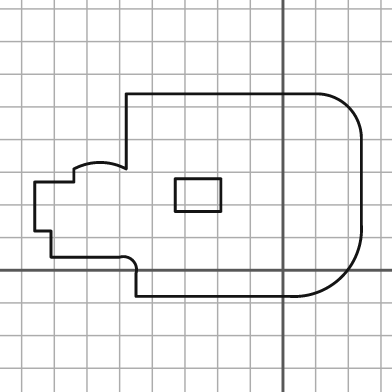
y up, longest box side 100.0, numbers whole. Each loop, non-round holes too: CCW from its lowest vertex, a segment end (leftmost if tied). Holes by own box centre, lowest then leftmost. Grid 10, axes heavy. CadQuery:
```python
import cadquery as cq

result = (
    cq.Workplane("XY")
    .moveTo(-45.0, -8.0)
    .lineTo(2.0, -8.0)
    .threePointArc((18.0, -2.0), (24.0, 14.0))
    .lineTo(24.0, 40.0)
    .threePointArc((20.0, 50.0), (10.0, 54.0))
    .lineTo(-48.0, 54.0)
    .lineTo(-48.0, 31.0)
    .threePointArc((-56.0, 33.0), (-64.0, 31.0))
    .lineTo(-64.0, 27.0)
    .lineTo(-76.0, 27.0)
    .lineTo(-76.0, 12.0)
    .lineTo(-71.0, 12.0)
    .lineTo(-71.0, 4.0)
    .lineTo(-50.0, 4.0)
    .threePointArc((-46.0, 3.0), (-45.0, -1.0))
    .close()
    .moveTo(-33.0, 18.0)
    .lineTo(-19.0, 18.0)
    .lineTo(-19.0, 28.0)
    .lineTo(-33.0, 28.0)
    .close()
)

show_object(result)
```